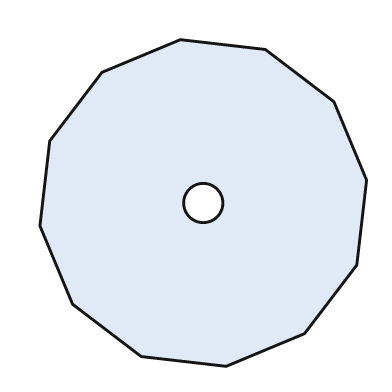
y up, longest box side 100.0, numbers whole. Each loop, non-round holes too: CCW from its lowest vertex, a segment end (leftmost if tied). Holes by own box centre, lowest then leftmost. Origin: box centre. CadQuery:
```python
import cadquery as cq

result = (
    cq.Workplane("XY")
    .moveTo(7.0, -50.0)
    .lineTo(31.0, -40.0)
    .lineTo(47.0, -19.0)
    .lineTo(50.0, 7.0)
    .lineTo(40.0, 31.0)
    .lineTo(19.0, 47.0)
    .lineTo(-7.0, 50.0)
    .lineTo(-31.0, 40.0)
    .lineTo(-47.0, 19.0)
    .lineTo(-50.0, -7.0)
    .lineTo(-40.0, -31.0)
    .lineTo(-19.0, -47.0)
    .close()
    .moveTo(0.0, 0.0)
    .circle(6.0)
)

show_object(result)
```